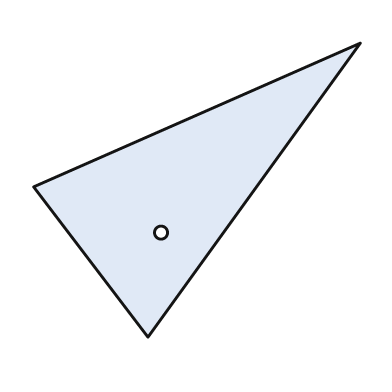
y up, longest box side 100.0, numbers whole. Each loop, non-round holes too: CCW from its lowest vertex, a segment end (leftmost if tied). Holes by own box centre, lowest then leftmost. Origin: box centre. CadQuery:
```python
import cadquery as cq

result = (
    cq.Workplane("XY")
    .moveTo(-15.0, -45.0)
    .lineTo(50.0, 45.0)
    .lineTo(-50.0, 1.0)
    .close()
    .moveTo(-11.0, -13.0)
    .circle(2.0)
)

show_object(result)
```